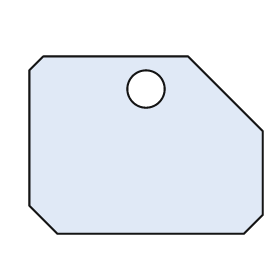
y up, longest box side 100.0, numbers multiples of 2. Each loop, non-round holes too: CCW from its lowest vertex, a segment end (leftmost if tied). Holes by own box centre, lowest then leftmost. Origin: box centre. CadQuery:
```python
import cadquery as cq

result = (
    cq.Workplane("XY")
    .moveTo(-38.0, -38.0)
    .lineTo(42.0, -38.0)
    .lineTo(50.0, -30.0)
    .lineTo(50.0, 6.0)
    .lineTo(18.0, 38.0)
    .lineTo(-44.0, 38.0)
    .lineTo(-50.0, 32.0)
    .lineTo(-50.0, -26.0)
    .close()
    .moveTo(0.0, 24.0)
    .circle(8.0)
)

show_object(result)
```